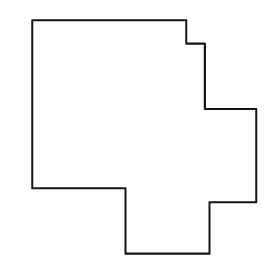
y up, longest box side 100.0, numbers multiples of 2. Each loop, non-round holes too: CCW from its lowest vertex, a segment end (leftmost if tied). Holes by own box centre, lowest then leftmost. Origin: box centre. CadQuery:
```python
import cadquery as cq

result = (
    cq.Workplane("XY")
    .moveTo(-8.0, -50.0)
    .lineTo(28.0, -50.0)
    .lineTo(28.0, -28.0)
    .lineTo(48.0, -28.0)
    .lineTo(48.0, 12.0)
    .lineTo(26.0, 12.0)
    .lineTo(26.0, 40.0)
    .lineTo(18.0, 40.0)
    .lineTo(18.0, 50.0)
    .lineTo(-48.0, 50.0)
    .lineTo(-48.0, -22.0)
    .lineTo(-8.0, -22.0)
    .close()
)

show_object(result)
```